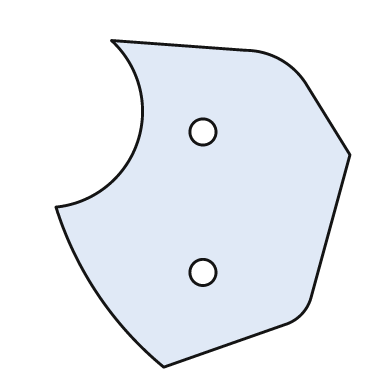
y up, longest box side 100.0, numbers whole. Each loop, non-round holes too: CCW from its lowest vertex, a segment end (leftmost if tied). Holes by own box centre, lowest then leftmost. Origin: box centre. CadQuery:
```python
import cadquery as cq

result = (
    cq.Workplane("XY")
    .moveTo(-12.0, -50.0)
    .lineTo(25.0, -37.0)
    .threePointArc((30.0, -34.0), (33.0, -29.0))
    .lineTo(45.0, 15.0)
    .lineTo(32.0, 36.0)
    .threePointArc((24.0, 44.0), (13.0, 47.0))
    .lineTo(-28.0, 50.0)
    .threePointArc((-20.0, 19.0), (-45.0, -1.0))
    .threePointArc((-32.0, -28.0), (-12.0, -50.0))
    .close()
    .moveTo(0.0, -21.0)
    .circle(4.0)
    .moveTo(0.0, 22.0)
    .circle(4.0)
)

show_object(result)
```